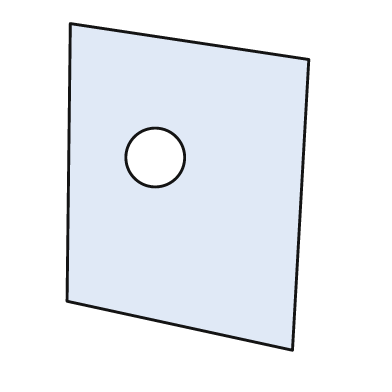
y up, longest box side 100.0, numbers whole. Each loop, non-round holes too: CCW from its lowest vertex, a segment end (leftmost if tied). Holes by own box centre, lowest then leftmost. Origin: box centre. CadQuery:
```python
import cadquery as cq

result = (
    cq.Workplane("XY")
    .moveTo(32.0, -50.0)
    .lineTo(37.0, 39.0)
    .lineTo(-36.0, 50.0)
    .lineTo(-37.0, -35.0)
    .close()
    .moveTo(-10.0, 9.0)
    .circle(9.0)
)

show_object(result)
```